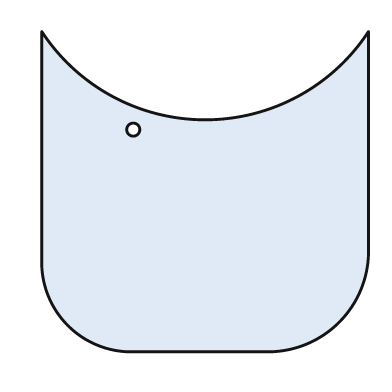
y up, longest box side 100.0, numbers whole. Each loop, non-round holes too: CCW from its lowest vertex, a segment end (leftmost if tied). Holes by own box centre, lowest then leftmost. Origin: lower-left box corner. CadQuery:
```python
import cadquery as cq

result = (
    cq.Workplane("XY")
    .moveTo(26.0, 0.0)
    .lineTo(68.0, 0.0)
    .threePointArc((91.0, 9.0), (100.0, 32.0))
    .lineTo(100.0, 98.0)
    .threePointArc((50.0, 71.0), (0.0, 98.0))
    .lineTo(0.0, 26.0)
    .threePointArc((8.0, 8.0), (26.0, 0.0))
    .close()
    .moveTo(28.0, 68.0)
    .circle(2.0)
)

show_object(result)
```